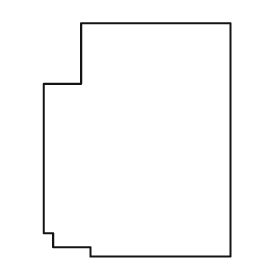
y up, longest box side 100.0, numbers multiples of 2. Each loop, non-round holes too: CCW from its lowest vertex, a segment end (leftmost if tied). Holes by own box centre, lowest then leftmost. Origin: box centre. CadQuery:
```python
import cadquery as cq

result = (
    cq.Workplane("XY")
    .moveTo(-20.0, -50.0)
    .lineTo(40.0, -50.0)
    .lineTo(40.0, 50.0)
    .lineTo(-24.0, 50.0)
    .lineTo(-24.0, 24.0)
    .lineTo(-40.0, 24.0)
    .lineTo(-40.0, -40.0)
    .lineTo(-36.0, -40.0)
    .lineTo(-36.0, -46.0)
    .lineTo(-20.0, -46.0)
    .close()
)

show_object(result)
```